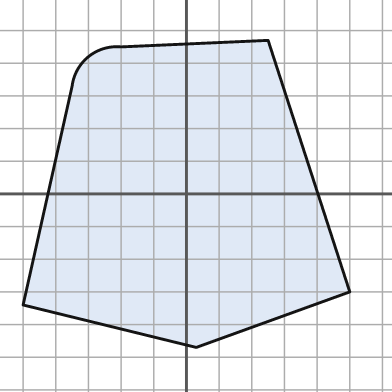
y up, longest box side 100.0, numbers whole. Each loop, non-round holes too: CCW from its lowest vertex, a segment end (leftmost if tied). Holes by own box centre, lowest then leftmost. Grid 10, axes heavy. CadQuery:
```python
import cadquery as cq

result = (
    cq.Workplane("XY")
    .moveTo(3.0, -47.0)
    .lineTo(50.0, -30.0)
    .lineTo(25.0, 47.0)
    .lineTo(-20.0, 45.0)
    .threePointArc((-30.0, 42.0), (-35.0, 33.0))
    .lineTo(-50.0, -34.0)
    .close()
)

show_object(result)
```